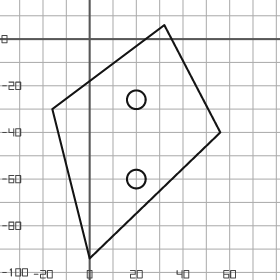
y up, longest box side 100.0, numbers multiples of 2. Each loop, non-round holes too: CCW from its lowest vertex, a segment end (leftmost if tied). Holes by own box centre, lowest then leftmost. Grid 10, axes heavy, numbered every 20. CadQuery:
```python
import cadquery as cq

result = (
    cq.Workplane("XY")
    .moveTo(0.0, -94.0)
    .lineTo(56.0, -40.0)
    .lineTo(32.0, 6.0)
    .lineTo(-16.0, -30.0)
    .close()
    .moveTo(20.0, -60.0)
    .circle(4.0)
    .moveTo(20.0, -26.0)
    .circle(4.0)
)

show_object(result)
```